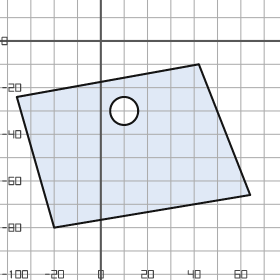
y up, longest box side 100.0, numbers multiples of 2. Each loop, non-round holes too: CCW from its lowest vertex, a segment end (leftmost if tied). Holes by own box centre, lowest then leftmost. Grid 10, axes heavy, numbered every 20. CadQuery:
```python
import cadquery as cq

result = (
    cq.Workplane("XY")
    .moveTo(-20.0, -80.0)
    .lineTo(64.0, -66.0)
    .lineTo(42.0, -10.0)
    .lineTo(-36.0, -24.0)
    .close()
    .moveTo(10.0, -30.0)
    .circle(6.0)
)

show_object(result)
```